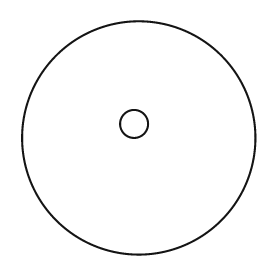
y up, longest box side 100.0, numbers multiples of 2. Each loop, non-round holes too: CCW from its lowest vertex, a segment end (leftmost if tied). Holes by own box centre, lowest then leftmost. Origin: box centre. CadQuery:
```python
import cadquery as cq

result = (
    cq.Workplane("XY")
    .moveTo(0.0, 0.0)
    .circle(50.0)
    .moveTo(-2.0, 6.0)
    .circle(6.0)
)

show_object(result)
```